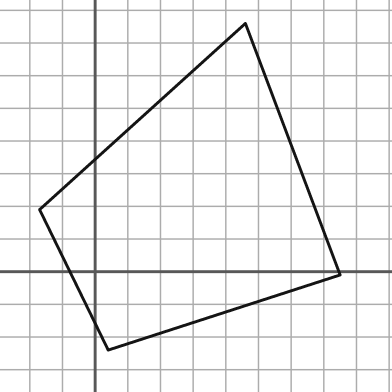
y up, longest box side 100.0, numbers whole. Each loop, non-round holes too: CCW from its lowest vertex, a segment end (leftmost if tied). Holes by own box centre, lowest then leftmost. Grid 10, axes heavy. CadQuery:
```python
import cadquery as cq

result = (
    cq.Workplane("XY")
    .moveTo(4.0, -24.0)
    .lineTo(75.0, -1.0)
    .lineTo(46.0, 76.0)
    .lineTo(-17.0, 19.0)
    .close()
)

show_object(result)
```